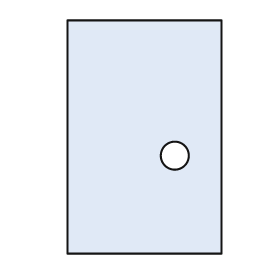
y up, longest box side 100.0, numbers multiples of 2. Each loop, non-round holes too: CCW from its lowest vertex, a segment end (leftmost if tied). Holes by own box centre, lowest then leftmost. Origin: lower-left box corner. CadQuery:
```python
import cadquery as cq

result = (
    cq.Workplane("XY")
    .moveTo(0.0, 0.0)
    .lineTo(66.0, 0.0)
    .lineTo(66.0, 100.0)
    .lineTo(0.0, 100.0)
    .close()
    .moveTo(46.0, 42.0)
    .circle(6.0)
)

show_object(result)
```